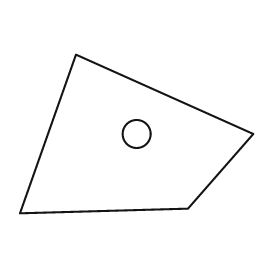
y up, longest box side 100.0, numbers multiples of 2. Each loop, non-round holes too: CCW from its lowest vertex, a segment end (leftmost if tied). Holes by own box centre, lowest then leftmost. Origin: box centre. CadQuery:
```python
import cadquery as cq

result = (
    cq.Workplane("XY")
    .moveTo(-50.0, -34.0)
    .lineTo(22.0, -32.0)
    .lineTo(50.0, 0.0)
    .lineTo(-26.0, 34.0)
    .close()
    .moveTo(0.0, 0.0)
    .circle(6.0)
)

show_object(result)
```